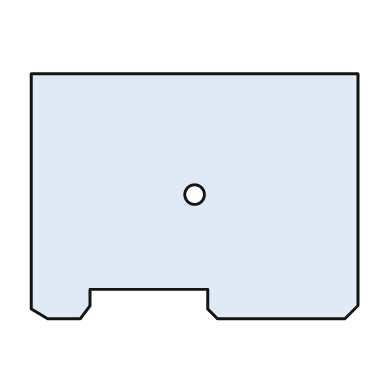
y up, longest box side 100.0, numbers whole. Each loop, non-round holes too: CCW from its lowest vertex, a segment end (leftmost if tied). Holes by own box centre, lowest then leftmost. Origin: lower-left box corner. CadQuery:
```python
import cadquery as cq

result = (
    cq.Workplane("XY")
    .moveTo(5.0, 0.0)
    .lineTo(15.0, 0.0)
    .lineTo(18.0, 4.0)
    .lineTo(18.0, 9.0)
    .lineTo(54.0, 9.0)
    .lineTo(54.0, 3.0)
    .lineTo(57.0, 0.0)
    .lineTo(96.0, 0.0)
    .lineTo(100.0, 4.0)
    .lineTo(100.0, 75.0)
    .lineTo(0.0, 75.0)
    .lineTo(0.0, 3.0)
    .close()
    .moveTo(50.0, 38.0)
    .circle(3.0)
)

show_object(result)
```